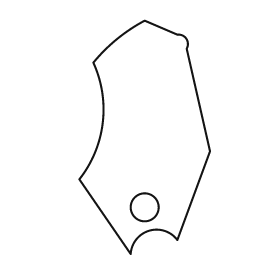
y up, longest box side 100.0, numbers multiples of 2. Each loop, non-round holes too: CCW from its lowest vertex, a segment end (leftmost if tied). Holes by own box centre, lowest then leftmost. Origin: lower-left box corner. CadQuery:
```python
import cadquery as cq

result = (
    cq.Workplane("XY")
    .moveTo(22.0, 0.0)
    .threePointArc((30.0, 10.0), (42.0, 6.0))
    .lineTo(56.0, 44.0)
    .lineTo(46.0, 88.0)
    .threePointArc((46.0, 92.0), (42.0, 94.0))
    .lineTo(28.0, 100.0)
    .threePointArc((16.0, 92.0), (6.0, 82.0))
    .threePointArc((10.0, 56.0), (0.0, 32.0))
    .close()
    .moveTo(28.0, 20.0)
    .circle(6.0)
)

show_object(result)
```